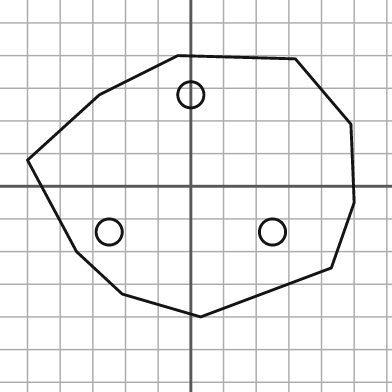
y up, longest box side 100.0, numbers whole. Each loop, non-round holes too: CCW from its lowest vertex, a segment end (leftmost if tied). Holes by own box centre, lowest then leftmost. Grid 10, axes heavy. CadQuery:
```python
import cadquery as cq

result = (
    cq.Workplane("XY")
    .moveTo(3.0, -40.0)
    .lineTo(43.0, -25.0)
    .lineTo(50.0, -5.0)
    .lineTo(49.0, 19.0)
    .lineTo(32.0, 39.0)
    .lineTo(-4.0, 40.0)
    .lineTo(-28.0, 28.0)
    .lineTo(-50.0, 8.0)
    .lineTo(-35.0, -20.0)
    .lineTo(-21.0, -33.0)
    .close()
    .moveTo(-25.0, -14.0)
    .circle(4.0)
    .moveTo(25.0, -14.0)
    .circle(4.0)
    .moveTo(0.0, 28.0)
    .circle(4.0)
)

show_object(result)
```